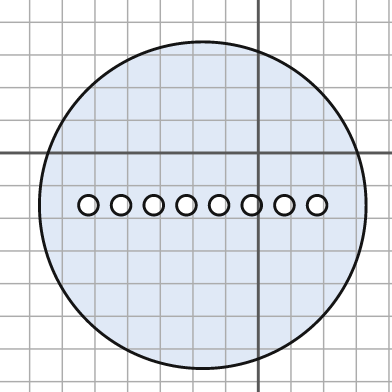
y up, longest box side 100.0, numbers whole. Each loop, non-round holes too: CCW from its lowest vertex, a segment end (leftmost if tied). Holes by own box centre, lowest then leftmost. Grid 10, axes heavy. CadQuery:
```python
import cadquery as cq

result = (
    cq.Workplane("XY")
    .moveTo(-17.0, -16.0)
    .circle(50.0)
    .moveTo(-52.0, -16.0)
    .circle(3.0)
    .moveTo(-42.0, -16.0)
    .circle(3.0)
    .moveTo(-32.0, -16.0)
    .circle(3.0)
    .moveTo(-22.0, -16.0)
    .circle(3.0)
    .moveTo(-12.0, -16.0)
    .circle(3.0)
    .moveTo(-2.0, -16.0)
    .circle(3.0)
    .moveTo(8.0, -16.0)
    .circle(3.0)
    .moveTo(18.0, -16.0)
    .circle(3.0)
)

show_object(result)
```